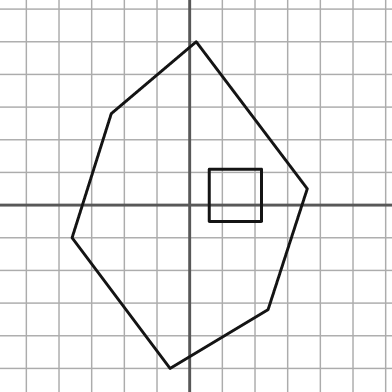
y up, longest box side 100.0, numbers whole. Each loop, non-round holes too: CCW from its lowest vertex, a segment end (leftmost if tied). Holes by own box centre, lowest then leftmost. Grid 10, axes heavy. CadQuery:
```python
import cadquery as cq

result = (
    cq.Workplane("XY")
    .moveTo(-6.0, -50.0)
    .lineTo(24.0, -32.0)
    .lineTo(36.0, 5.0)
    .lineTo(2.0, 50.0)
    .lineTo(-24.0, 28.0)
    .lineTo(-36.0, -10.0)
    .close()
    .moveTo(6.0, -5.0)
    .lineTo(22.0, -5.0)
    .lineTo(22.0, 11.0)
    .lineTo(6.0, 11.0)
    .close()
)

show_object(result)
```